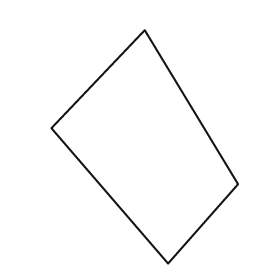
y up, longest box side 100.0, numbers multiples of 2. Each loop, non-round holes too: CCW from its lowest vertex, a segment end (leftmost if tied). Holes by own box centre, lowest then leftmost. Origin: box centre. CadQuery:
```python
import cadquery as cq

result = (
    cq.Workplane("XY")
    .moveTo(10.0, -50.0)
    .lineTo(40.0, -16.0)
    .lineTo(0.0, 50.0)
    .lineTo(-40.0, 8.0)
    .close()
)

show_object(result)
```